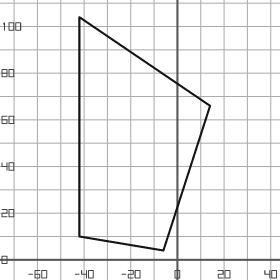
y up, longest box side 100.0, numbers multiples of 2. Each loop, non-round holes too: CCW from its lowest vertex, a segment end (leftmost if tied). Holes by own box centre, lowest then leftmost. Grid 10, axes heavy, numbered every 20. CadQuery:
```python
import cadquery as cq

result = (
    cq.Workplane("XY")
    .moveTo(-6.0, 4.0)
    .lineTo(14.0, 66.0)
    .lineTo(-42.0, 104.0)
    .lineTo(-42.0, 10.0)
    .close()
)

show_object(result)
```